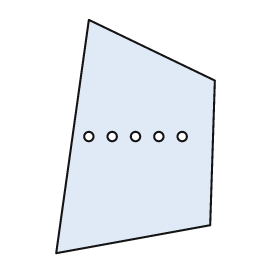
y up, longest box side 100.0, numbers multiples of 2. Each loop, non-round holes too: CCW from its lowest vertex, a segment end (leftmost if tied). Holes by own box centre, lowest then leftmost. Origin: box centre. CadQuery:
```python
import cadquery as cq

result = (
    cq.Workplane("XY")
    .moveTo(-34.0, -50.0)
    .lineTo(32.0, -38.0)
    .lineTo(34.0, 24.0)
    .lineTo(-20.0, 50.0)
    .close()
    .moveTo(-20.0, 0.0)
    .circle(2.0)
    .moveTo(-10.0, 0.0)
    .circle(2.0)
    .moveTo(0.0, 0.0)
    .circle(2.0)
    .moveTo(10.0, 0.0)
    .circle(2.0)
    .moveTo(20.0, 0.0)
    .circle(2.0)
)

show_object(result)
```